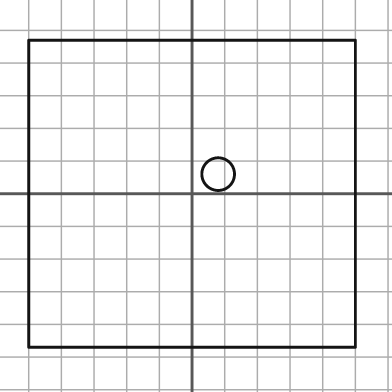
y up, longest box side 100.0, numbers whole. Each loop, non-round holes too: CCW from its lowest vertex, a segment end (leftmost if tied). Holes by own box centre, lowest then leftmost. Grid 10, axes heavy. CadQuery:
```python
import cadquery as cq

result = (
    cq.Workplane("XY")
    .moveTo(-50.0, -47.0)
    .lineTo(50.0, -47.0)
    .lineTo(50.0, 47.0)
    .lineTo(-50.0, 47.0)
    .close()
    .moveTo(8.0, 6.0)
    .circle(5.0)
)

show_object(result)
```